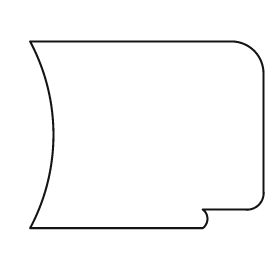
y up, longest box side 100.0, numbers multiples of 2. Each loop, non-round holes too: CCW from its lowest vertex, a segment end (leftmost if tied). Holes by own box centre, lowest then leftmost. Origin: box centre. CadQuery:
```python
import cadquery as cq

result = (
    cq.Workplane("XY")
    .moveTo(-50.0, -40.0)
    .lineTo(24.0, -40.0)
    .threePointArc((26.0, -36.0), (24.0, -32.0))
    .lineTo(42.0, -32.0)
    .threePointArc((48.0, -30.0), (50.0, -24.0))
    .lineTo(50.0, 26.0)
    .threePointArc((46.0, 36.0), (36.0, 40.0))
    .lineTo(-50.0, 40.0)
    .threePointArc((-40.0, 0.0), (-50.0, -40.0))
    .close()
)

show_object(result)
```